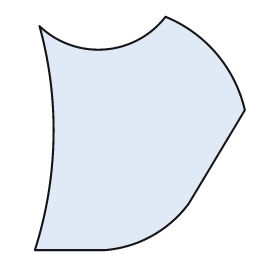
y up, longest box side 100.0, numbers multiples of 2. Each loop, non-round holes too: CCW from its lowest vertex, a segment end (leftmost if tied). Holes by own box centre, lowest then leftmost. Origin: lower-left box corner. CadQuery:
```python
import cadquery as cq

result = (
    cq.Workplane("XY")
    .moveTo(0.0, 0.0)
    .lineTo(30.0, 0.0)
    .threePointArc((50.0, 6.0), (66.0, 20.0))
    .lineTo(90.0, 60.0)
    .threePointArc((78.0, 84.0), (56.0, 100.0))
    .threePointArc((30.0, 86.0), (2.0, 96.0))
    .threePointArc((8.0, 48.0), (0.0, 0.0))
    .close()
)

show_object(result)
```